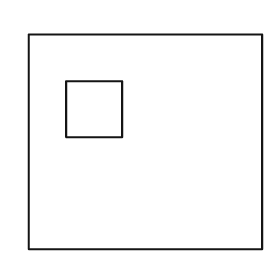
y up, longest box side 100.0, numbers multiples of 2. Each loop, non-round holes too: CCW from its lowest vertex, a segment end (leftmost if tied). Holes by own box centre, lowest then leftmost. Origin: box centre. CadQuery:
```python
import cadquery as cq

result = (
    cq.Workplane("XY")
    .moveTo(-50.0, -46.0)
    .lineTo(50.0, -46.0)
    .lineTo(50.0, 46.0)
    .lineTo(-50.0, 46.0)
    .close()
    .moveTo(-34.0, 2.0)
    .lineTo(-10.0, 2.0)
    .lineTo(-10.0, 26.0)
    .lineTo(-34.0, 26.0)
    .close()
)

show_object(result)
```